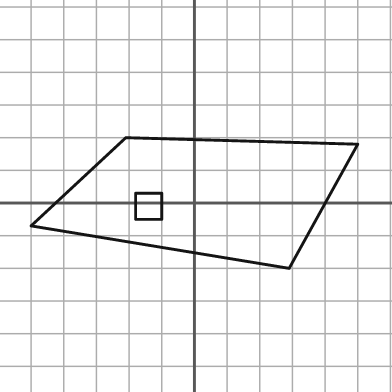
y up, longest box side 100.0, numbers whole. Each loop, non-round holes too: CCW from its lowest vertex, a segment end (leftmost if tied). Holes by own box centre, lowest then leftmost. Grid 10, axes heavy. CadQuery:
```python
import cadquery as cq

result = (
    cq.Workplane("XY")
    .moveTo(29.0, -20.0)
    .lineTo(50.0, 18.0)
    .lineTo(-21.0, 20.0)
    .lineTo(-50.0, -7.0)
    .close()
    .moveTo(-18.0, -5.0)
    .lineTo(-10.0, -5.0)
    .lineTo(-10.0, 3.0)
    .lineTo(-18.0, 3.0)
    .close()
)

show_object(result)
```